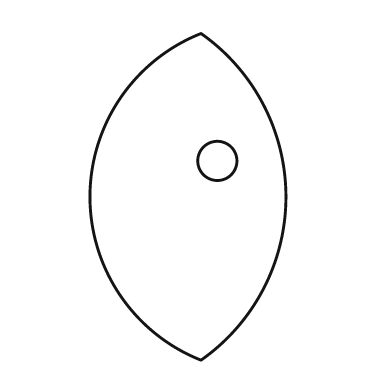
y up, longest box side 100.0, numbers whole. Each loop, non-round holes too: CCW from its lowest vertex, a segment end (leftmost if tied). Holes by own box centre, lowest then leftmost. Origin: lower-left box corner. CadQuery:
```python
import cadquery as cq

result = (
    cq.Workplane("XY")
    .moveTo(34.0, 0.0)
    .threePointArc((60.0, 50.0), (34.0, 100.0))
    .threePointArc((0.0, 50.0), (34.0, 0.0))
    .close()
    .moveTo(39.0, 61.0)
    .circle(6.0)
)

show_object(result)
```